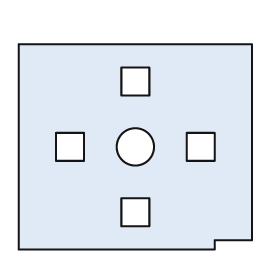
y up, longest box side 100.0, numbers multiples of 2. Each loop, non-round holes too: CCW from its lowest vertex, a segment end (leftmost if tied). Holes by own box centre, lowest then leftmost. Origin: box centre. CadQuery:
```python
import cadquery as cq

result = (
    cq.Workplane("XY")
    .moveTo(-50.0, -44.0)
    .lineTo(34.0, -44.0)
    .lineTo(34.0, -40.0)
    .lineTo(50.0, -40.0)
    .lineTo(50.0, 44.0)
    .lineTo(-50.0, 44.0)
    .close()
    .moveTo(-6.0, -34.0)
    .lineTo(6.0, -34.0)
    .lineTo(6.0, -22.0)
    .lineTo(-6.0, -22.0)
    .close()
    .moveTo(-34.0, -6.0)
    .lineTo(-22.0, -6.0)
    .lineTo(-22.0, 6.0)
    .lineTo(-34.0, 6.0)
    .close()
    .moveTo(0.0, 0.0)
    .circle(8.0)
    .moveTo(22.0, -6.0)
    .lineTo(34.0, -6.0)
    .lineTo(34.0, 6.0)
    .lineTo(22.0, 6.0)
    .close()
    .moveTo(-6.0, 22.0)
    .lineTo(6.0, 22.0)
    .lineTo(6.0, 34.0)
    .lineTo(-6.0, 34.0)
    .close()
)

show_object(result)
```